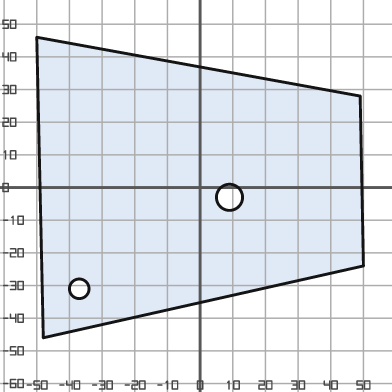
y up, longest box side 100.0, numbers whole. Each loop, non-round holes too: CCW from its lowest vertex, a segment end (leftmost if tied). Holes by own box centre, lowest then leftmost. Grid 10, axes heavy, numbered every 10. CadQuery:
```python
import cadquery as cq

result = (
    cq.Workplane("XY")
    .moveTo(-48.0, -46.0)
    .lineTo(50.0, -24.0)
    .lineTo(49.0, 28.0)
    .lineTo(-50.0, 46.0)
    .close()
    .moveTo(-37.0, -31.0)
    .circle(3.0)
    .moveTo(9.0, -3.0)
    .circle(4.0)
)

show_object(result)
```